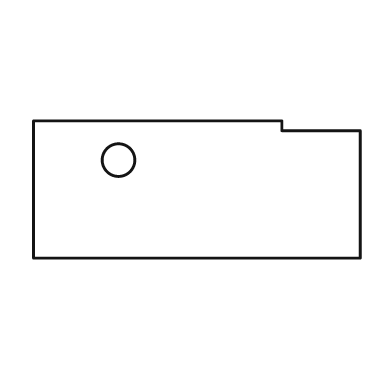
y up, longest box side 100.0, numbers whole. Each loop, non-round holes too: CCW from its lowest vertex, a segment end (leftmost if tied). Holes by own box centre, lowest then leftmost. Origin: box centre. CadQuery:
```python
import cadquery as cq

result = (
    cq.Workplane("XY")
    .moveTo(-50.0, -21.0)
    .lineTo(50.0, -21.0)
    .lineTo(50.0, 18.0)
    .lineTo(26.0, 18.0)
    .lineTo(26.0, 21.0)
    .lineTo(-50.0, 21.0)
    .close()
    .moveTo(-24.0, 9.0)
    .circle(5.0)
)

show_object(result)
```